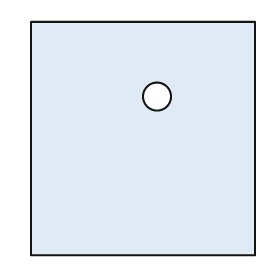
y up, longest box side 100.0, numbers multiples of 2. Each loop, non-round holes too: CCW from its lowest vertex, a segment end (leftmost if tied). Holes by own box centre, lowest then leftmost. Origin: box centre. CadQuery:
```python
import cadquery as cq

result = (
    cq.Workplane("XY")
    .moveTo(-48.0, -50.0)
    .lineTo(48.0, -50.0)
    .lineTo(48.0, 50.0)
    .lineTo(-48.0, 50.0)
    .close()
    .moveTo(6.0, 18.0)
    .circle(6.0)
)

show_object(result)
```